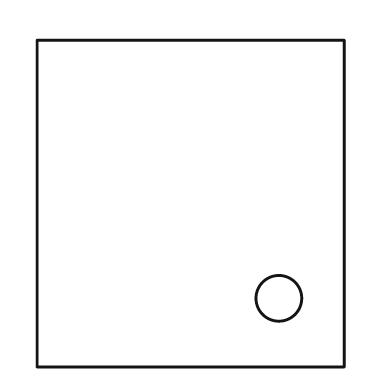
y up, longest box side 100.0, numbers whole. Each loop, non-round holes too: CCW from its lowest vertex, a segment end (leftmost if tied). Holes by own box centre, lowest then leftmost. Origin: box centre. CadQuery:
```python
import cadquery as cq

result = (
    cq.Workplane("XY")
    .moveTo(-47.0, -50.0)
    .lineTo(47.0, -50.0)
    .lineTo(47.0, 50.0)
    .lineTo(-47.0, 50.0)
    .close()
    .moveTo(27.0, -29.0)
    .circle(7.0)
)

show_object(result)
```